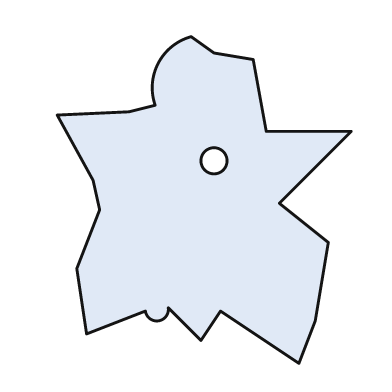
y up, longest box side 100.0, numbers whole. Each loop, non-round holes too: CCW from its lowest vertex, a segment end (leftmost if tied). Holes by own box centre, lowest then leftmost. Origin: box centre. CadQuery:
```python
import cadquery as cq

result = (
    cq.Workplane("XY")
    .moveTo(29.0, -50.0)
    .lineTo(34.0, -37.0)
    .lineTo(38.0, -13.0)
    .lineTo(23.0, -1.0)
    .lineTo(45.0, 21.0)
    .lineTo(19.0, 21.0)
    .lineTo(15.0, 43.0)
    .lineTo(3.0, 45.0)
    .lineTo(-4.0, 50.0)
    .threePointArc((-14.0, 42.0), (-15.0, 29.0))
    .lineTo(-23.0, 27.0)
    .lineTo(-45.0, 26.0)
    .lineTo(-34.0, 6.0)
    .lineTo(-32.0, -3.0)
    .lineTo(-39.0, -21.0)
    .lineTo(-36.0, -41.0)
    .lineTo(-18.0, -34.0)
    .threePointArc((-14.0, -37.0), (-11.0, -33.0))
    .lineTo(-1.0, -43.0)
    .lineTo(5.0, -34.0)
    .close()
    .moveTo(3.0, 12.0)
    .circle(4.0)
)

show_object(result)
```